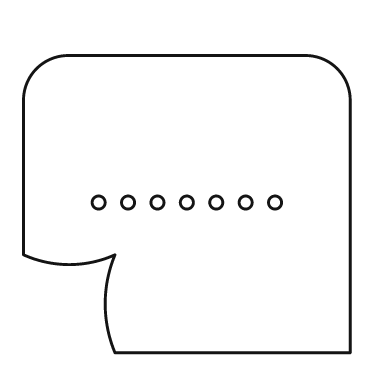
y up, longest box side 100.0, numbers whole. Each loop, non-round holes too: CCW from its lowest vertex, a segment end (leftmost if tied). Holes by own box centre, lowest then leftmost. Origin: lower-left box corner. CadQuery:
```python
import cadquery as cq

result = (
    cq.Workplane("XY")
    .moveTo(28.0, 0.0)
    .lineTo(100.0, 0.0)
    .lineTo(100.0, 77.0)
    .threePointArc((96.0, 87.0), (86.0, 91.0))
    .lineTo(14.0, 91.0)
    .threePointArc((4.0, 87.0), (0.0, 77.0))
    .lineTo(0.0, 30.0)
    .threePointArc((14.0, 27.0), (28.0, 30.0))
    .threePointArc((25.0, 15.0), (28.0, 0.0))
    .close()
    .moveTo(23.0, 46.0)
    .circle(2.0)
    .moveTo(32.0, 46.0)
    .circle(2.0)
    .moveTo(41.0, 46.0)
    .circle(2.0)
    .moveTo(50.0, 46.0)
    .circle(2.0)
    .moveTo(59.0, 46.0)
    .circle(2.0)
    .moveTo(68.0, 46.0)
    .circle(2.0)
    .moveTo(77.0, 46.0)
    .circle(2.0)
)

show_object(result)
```